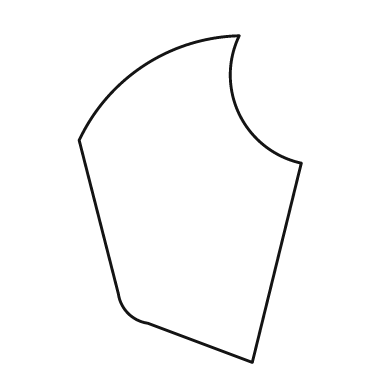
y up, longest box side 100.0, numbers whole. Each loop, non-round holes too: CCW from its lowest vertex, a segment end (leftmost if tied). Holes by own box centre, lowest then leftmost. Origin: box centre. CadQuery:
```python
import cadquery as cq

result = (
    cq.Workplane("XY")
    .moveTo(19.0, -50.0)
    .lineTo(34.0, 11.0)
    .threePointArc((15.0, 26.0), (15.0, 50.0))
    .threePointArc((-14.0, 41.0), (-34.0, 18.0))
    .lineTo(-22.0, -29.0)
    .threePointArc((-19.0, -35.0), (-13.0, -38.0))
    .close()
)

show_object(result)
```